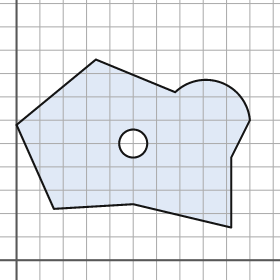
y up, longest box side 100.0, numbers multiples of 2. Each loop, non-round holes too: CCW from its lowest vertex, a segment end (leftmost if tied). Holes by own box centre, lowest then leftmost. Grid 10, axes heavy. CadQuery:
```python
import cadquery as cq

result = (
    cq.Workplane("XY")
    .moveTo(92.0, 14.0)
    .lineTo(92.0, 44.0)
    .lineTo(100.0, 60.0)
    .threePointArc((88.0, 76.0), (68.0, 72.0))
    .lineTo(34.0, 86.0)
    .lineTo(0.0, 58.0)
    .lineTo(16.0, 22.0)
    .lineTo(50.0, 24.0)
    .close()
    .moveTo(50.0, 50.0)
    .circle(6.0)
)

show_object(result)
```